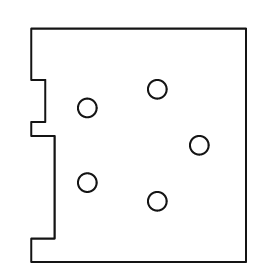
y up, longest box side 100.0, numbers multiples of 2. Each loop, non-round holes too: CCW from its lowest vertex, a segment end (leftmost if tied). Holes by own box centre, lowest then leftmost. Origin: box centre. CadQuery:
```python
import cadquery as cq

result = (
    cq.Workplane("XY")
    .moveTo(-46.0, -50.0)
    .lineTo(46.0, -50.0)
    .lineTo(46.0, 50.0)
    .lineTo(-46.0, 50.0)
    .lineTo(-46.0, 28.0)
    .lineTo(-40.0, 28.0)
    .lineTo(-40.0, 10.0)
    .lineTo(-46.0, 10.0)
    .lineTo(-46.0, 4.0)
    .lineTo(-36.0, 4.0)
    .lineTo(-36.0, -40.0)
    .lineTo(-46.0, -40.0)
    .close()
    .moveTo(8.0, -24.0)
    .circle(4.0)
    .moveTo(-22.0, -16.0)
    .circle(4.0)
    .moveTo(26.0, 0.0)
    .circle(4.0)
    .moveTo(-22.0, 16.0)
    .circle(4.0)
    .moveTo(8.0, 24.0)
    .circle(4.0)
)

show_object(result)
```